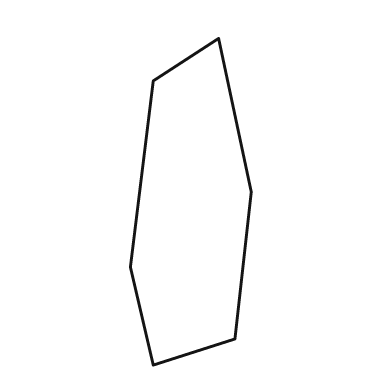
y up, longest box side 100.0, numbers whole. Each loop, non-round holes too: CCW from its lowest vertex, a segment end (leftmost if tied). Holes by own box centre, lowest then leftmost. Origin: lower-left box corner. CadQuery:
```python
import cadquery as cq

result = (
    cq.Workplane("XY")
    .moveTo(7.0, 0.0)
    .lineTo(32.0, 8.0)
    .lineTo(37.0, 53.0)
    .lineTo(27.0, 100.0)
    .lineTo(7.0, 87.0)
    .lineTo(0.0, 30.0)
    .close()
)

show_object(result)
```